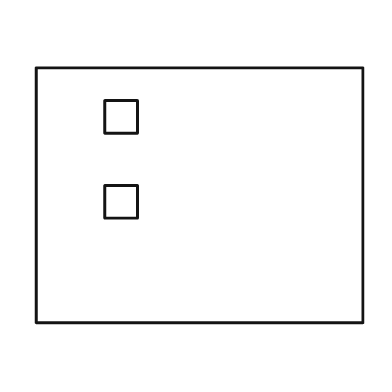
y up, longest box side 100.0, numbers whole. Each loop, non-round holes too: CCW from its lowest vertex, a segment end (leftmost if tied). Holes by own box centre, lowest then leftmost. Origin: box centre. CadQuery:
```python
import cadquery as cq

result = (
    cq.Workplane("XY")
    .moveTo(-50.0, -39.0)
    .lineTo(50.0, -39.0)
    .lineTo(50.0, 39.0)
    .lineTo(-50.0, 39.0)
    .close()
    .moveTo(-29.0, -7.0)
    .lineTo(-19.0, -7.0)
    .lineTo(-19.0, 3.0)
    .lineTo(-29.0, 3.0)
    .close()
    .moveTo(-29.0, 19.0)
    .lineTo(-19.0, 19.0)
    .lineTo(-19.0, 29.0)
    .lineTo(-29.0, 29.0)
    .close()
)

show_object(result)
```